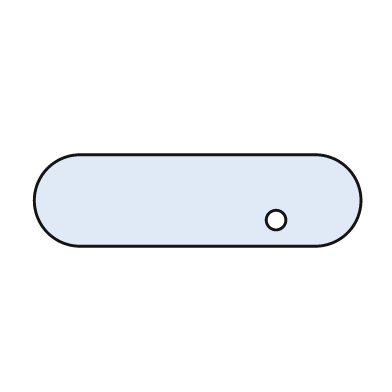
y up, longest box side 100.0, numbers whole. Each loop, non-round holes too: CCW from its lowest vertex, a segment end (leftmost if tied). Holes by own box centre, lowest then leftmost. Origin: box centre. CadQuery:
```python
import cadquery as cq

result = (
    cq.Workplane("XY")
    .moveTo(-36.0, -14.0)
    .lineTo(36.0, -14.0)
    .threePointArc((50.0, 0.0), (36.0, 14.0))
    .lineTo(-36.0, 14.0)
    .threePointArc((-50.0, 0.0), (-36.0, -14.0))
    .close()
    .moveTo(24.0, -6.0)
    .circle(3.0)
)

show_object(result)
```